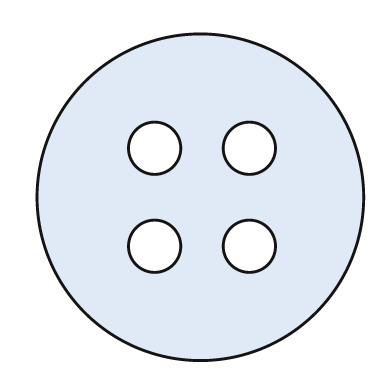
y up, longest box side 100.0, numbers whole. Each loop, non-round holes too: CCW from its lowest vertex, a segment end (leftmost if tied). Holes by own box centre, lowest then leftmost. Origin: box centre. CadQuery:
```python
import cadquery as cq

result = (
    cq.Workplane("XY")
    .moveTo(0.0, 0.0)
    .circle(50.0)
    .moveTo(-14.0, -15.0)
    .circle(8.0)
    .moveTo(15.0, -15.0)
    .circle(8.0)
    .moveTo(-14.0, 15.0)
    .circle(8.0)
    .moveTo(15.0, 15.0)
    .circle(8.0)
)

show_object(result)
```